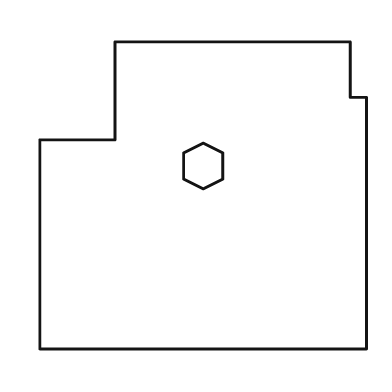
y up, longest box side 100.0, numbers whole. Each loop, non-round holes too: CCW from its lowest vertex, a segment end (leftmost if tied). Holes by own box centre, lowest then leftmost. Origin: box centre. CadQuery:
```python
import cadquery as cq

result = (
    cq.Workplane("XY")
    .moveTo(-50.0, -47.0)
    .lineTo(50.0, -47.0)
    .lineTo(50.0, 30.0)
    .lineTo(45.0, 30.0)
    .lineTo(45.0, 47.0)
    .lineTo(-27.0, 47.0)
    .lineTo(-27.0, 17.0)
    .lineTo(-50.0, 17.0)
    .close()
    .moveTo(0.0, 2.0)
    .lineTo(6.0, 5.0)
    .lineTo(6.0, 13.0)
    .lineTo(0.0, 16.0)
    .lineTo(-6.0, 13.0)
    .lineTo(-6.0, 5.0)
    .close()
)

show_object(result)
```